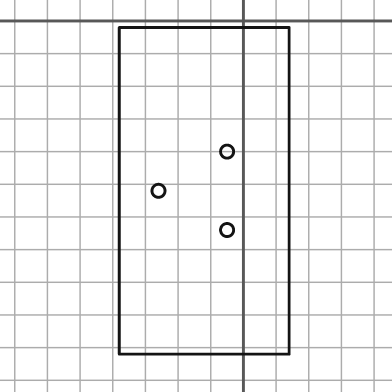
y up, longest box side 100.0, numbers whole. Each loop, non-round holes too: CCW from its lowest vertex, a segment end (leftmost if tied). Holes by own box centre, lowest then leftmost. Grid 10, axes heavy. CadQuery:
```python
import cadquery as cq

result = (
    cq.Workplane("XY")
    .moveTo(-38.0, -102.0)
    .lineTo(14.0, -102.0)
    .lineTo(14.0, -2.0)
    .lineTo(-38.0, -2.0)
    .close()
    .moveTo(-5.0, -64.0)
    .circle(2.0)
    .moveTo(-26.0, -52.0)
    .circle(2.0)
    .moveTo(-5.0, -40.0)
    .circle(2.0)
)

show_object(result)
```